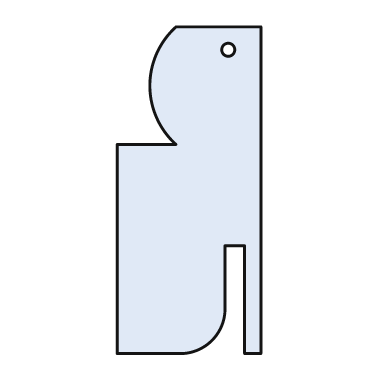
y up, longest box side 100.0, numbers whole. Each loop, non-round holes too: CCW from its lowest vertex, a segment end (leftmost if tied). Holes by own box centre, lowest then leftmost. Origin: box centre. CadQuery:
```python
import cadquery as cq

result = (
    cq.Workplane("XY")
    .moveTo(-22.0, -50.0)
    .lineTo(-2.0, -50.0)
    .threePointArc((7.0, -46.0), (11.0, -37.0))
    .lineTo(11.0, -17.0)
    .lineTo(17.0, -17.0)
    .lineTo(17.0, -50.0)
    .lineTo(22.0, -50.0)
    .lineTo(22.0, 50.0)
    .lineTo(-4.0, 50.0)
    .threePointArc((-12.0, 32.0), (-4.0, 14.0))
    .lineTo(-22.0, 14.0)
    .close()
    .moveTo(12.0, 43.0)
    .circle(2.0)
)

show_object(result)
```